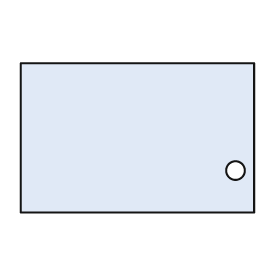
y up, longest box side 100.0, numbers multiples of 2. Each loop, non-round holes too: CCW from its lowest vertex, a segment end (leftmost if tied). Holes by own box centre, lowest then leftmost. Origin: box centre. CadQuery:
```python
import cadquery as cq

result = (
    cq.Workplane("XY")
    .moveTo(-50.0, -32.0)
    .lineTo(50.0, -32.0)
    .lineTo(50.0, 32.0)
    .lineTo(-50.0, 32.0)
    .close()
    .moveTo(42.0, -14.0)
    .circle(4.0)
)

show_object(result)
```